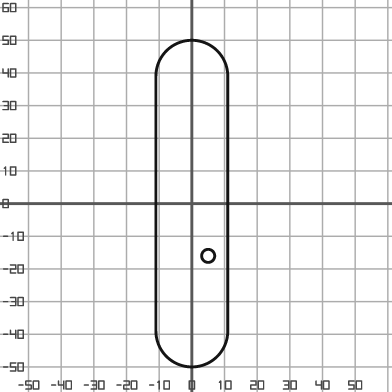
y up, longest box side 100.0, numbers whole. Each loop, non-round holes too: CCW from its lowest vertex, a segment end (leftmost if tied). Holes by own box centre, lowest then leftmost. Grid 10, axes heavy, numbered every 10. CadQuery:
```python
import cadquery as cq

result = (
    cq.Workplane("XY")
    .moveTo(-11.0, -39.0)
    .threePointArc((0.0, -50.0), (11.0, -39.0))
    .lineTo(11.0, 39.0)
    .threePointArc((0.0, 50.0), (-11.0, 39.0))
    .close()
    .moveTo(5.0, -16.0)
    .circle(2.0)
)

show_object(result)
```